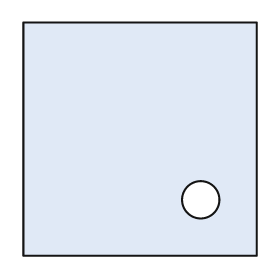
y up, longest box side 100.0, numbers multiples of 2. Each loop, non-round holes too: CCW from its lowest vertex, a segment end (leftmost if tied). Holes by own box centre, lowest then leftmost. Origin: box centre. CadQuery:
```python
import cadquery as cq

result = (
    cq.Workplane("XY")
    .moveTo(-50.0, -50.0)
    .lineTo(50.0, -50.0)
    .lineTo(50.0, 50.0)
    .lineTo(-50.0, 50.0)
    .close()
    .moveTo(26.0, -26.0)
    .circle(8.0)
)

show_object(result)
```